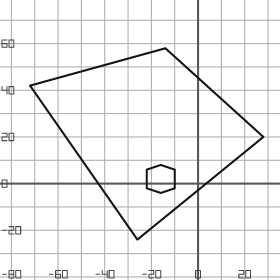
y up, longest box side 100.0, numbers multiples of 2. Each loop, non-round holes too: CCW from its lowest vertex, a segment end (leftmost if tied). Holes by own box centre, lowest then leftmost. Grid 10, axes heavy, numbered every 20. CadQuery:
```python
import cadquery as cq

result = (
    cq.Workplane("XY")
    .moveTo(-26.0, -24.0)
    .lineTo(28.0, 20.0)
    .lineTo(-14.0, 58.0)
    .lineTo(-72.0, 42.0)
    .close()
    .moveTo(-16.0, -4.0)
    .lineTo(-10.0, -2.0)
    .lineTo(-10.0, 6.0)
    .lineTo(-16.0, 8.0)
    .lineTo(-22.0, 6.0)
    .lineTo(-22.0, -2.0)
    .close()
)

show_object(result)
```